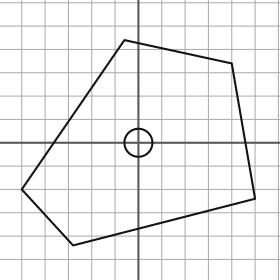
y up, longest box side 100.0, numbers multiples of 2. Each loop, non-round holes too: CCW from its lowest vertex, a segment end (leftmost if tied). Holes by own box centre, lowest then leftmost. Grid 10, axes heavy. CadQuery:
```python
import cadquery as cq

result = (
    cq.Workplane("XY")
    .moveTo(-28.0, -44.0)
    .lineTo(50.0, -24.0)
    .lineTo(40.0, 34.0)
    .lineTo(-6.0, 44.0)
    .lineTo(-50.0, -20.0)
    .close()
    .moveTo(0.0, 0.0)
    .circle(6.0)
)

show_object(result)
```